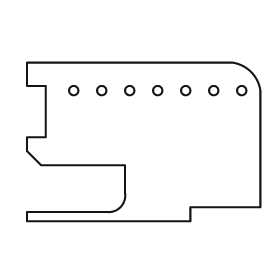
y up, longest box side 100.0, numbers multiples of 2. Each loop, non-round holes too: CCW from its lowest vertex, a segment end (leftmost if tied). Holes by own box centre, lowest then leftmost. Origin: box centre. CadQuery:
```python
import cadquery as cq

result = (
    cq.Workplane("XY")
    .moveTo(-50.0, -34.0)
    .lineTo(20.0, -34.0)
    .lineTo(20.0, -28.0)
    .lineTo(50.0, -28.0)
    .lineTo(50.0, 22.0)
    .threePointArc((46.0, 30.0), (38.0, 34.0))
    .lineTo(-50.0, 34.0)
    .lineTo(-50.0, 24.0)
    .lineTo(-42.0, 24.0)
    .lineTo(-42.0, 2.0)
    .lineTo(-50.0, 2.0)
    .lineTo(-50.0, -4.0)
    .lineTo(-44.0, -10.0)
    .lineTo(-8.0, -10.0)
    .lineTo(-8.0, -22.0)
    .threePointArc((-10.0, -28.0), (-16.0, -30.0))
    .lineTo(-50.0, -30.0)
    .close()
    .moveTo(-30.0, 22.0)
    .circle(2.0)
    .moveTo(-18.0, 22.0)
    .circle(2.0)
    .moveTo(-6.0, 22.0)
    .circle(2.0)
    .moveTo(6.0, 22.0)
    .circle(2.0)
    .moveTo(18.0, 22.0)
    .circle(2.0)
    .moveTo(30.0, 22.0)
    .circle(2.0)
    .moveTo(42.0, 22.0)
    .circle(2.0)
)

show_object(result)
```